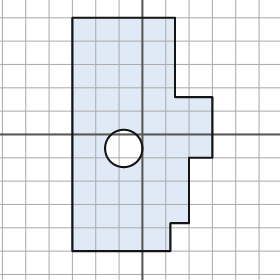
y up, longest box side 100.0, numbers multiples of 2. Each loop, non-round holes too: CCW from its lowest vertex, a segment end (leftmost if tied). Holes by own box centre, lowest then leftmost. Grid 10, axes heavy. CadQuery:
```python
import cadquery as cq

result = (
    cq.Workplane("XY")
    .moveTo(-30.0, -50.0)
    .lineTo(12.0, -50.0)
    .lineTo(12.0, -38.0)
    .lineTo(20.0, -38.0)
    .lineTo(20.0, -10.0)
    .lineTo(30.0, -10.0)
    .lineTo(30.0, 16.0)
    .lineTo(14.0, 16.0)
    .lineTo(14.0, 50.0)
    .lineTo(-30.0, 50.0)
    .close()
    .moveTo(-8.0, -6.0)
    .circle(8.0)
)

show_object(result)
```